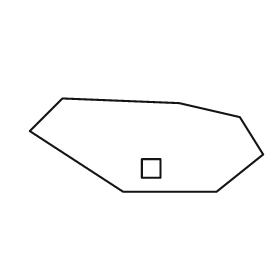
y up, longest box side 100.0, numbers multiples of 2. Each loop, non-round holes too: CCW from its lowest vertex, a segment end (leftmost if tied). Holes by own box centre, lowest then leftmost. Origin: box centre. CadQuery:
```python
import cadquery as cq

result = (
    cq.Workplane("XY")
    .moveTo(-10.0, -20.0)
    .lineTo(30.0, -20.0)
    .lineTo(50.0, -4.0)
    .lineTo(40.0, 12.0)
    .lineTo(14.0, 18.0)
    .lineTo(-36.0, 20.0)
    .lineTo(-50.0, 6.0)
    .close()
    .moveTo(-2.0, -14.0)
    .lineTo(6.0, -14.0)
    .lineTo(6.0, -6.0)
    .lineTo(-2.0, -6.0)
    .close()
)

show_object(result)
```